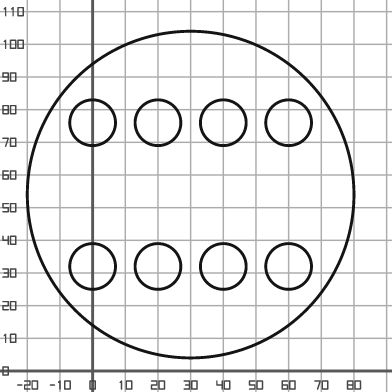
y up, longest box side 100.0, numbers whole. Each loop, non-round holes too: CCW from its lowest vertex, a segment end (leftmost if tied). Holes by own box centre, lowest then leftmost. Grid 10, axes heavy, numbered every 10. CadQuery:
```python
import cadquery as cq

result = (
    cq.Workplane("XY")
    .moveTo(30.0, 54.0)
    .circle(50.0)
    .moveTo(0.0, 32.0)
    .circle(7.0)
    .moveTo(20.0, 32.0)
    .circle(7.0)
    .moveTo(40.0, 32.0)
    .circle(7.0)
    .moveTo(60.0, 32.0)
    .circle(7.0)
    .moveTo(0.0, 76.0)
    .circle(7.0)
    .moveTo(20.0, 76.0)
    .circle(7.0)
    .moveTo(40.0, 76.0)
    .circle(7.0)
    .moveTo(60.0, 76.0)
    .circle(7.0)
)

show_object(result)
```